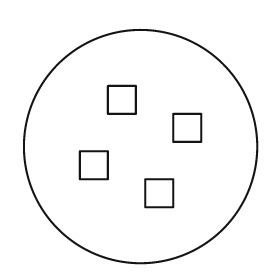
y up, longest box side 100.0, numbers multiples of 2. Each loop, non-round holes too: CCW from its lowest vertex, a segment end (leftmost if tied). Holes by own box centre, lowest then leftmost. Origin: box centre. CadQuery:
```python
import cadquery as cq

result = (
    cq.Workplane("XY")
    .moveTo(0.0, 0.0)
    .circle(50.0)
    .moveTo(2.0, -26.0)
    .lineTo(14.0, -26.0)
    .lineTo(14.0, -14.0)
    .lineTo(2.0, -14.0)
    .close()
    .moveTo(-26.0, -14.0)
    .lineTo(-14.0, -14.0)
    .lineTo(-14.0, -2.0)
    .lineTo(-26.0, -2.0)
    .close()
    .moveTo(14.0, 2.0)
    .lineTo(26.0, 2.0)
    .lineTo(26.0, 14.0)
    .lineTo(14.0, 14.0)
    .close()
    .moveTo(-14.0, 14.0)
    .lineTo(-2.0, 14.0)
    .lineTo(-2.0, 26.0)
    .lineTo(-14.0, 26.0)
    .close()
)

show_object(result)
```